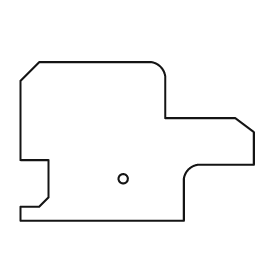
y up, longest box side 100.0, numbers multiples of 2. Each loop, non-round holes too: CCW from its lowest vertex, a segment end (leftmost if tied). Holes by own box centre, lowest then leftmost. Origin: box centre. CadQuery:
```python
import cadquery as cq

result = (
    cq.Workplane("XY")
    .moveTo(-50.0, -34.0)
    .lineTo(20.0, -34.0)
    .lineTo(20.0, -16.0)
    .threePointArc((22.0, -12.0), (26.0, -10.0))
    .lineTo(50.0, -10.0)
    .lineTo(50.0, 4.0)
    .lineTo(42.0, 10.0)
    .lineTo(12.0, 10.0)
    .lineTo(12.0, 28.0)
    .threePointArc((10.0, 32.0), (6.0, 34.0))
    .lineTo(-42.0, 34.0)
    .lineTo(-50.0, 26.0)
    .lineTo(-50.0, -8.0)
    .lineTo(-38.0, -8.0)
    .lineTo(-38.0, -24.0)
    .lineTo(-42.0, -28.0)
    .lineTo(-50.0, -28.0)
    .close()
    .moveTo(-6.0, -16.0)
    .circle(2.0)
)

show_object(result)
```